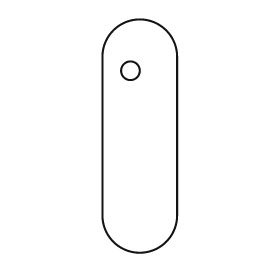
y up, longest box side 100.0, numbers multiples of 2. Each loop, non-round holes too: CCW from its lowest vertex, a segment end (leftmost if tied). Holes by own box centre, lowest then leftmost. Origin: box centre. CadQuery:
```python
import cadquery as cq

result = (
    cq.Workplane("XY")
    .moveTo(-16.0, -34.0)
    .threePointArc((0.0, -50.0), (16.0, -34.0))
    .lineTo(16.0, 34.0)
    .threePointArc((0.0, 50.0), (-16.0, 34.0))
    .close()
    .moveTo(-4.0, 28.0)
    .circle(4.0)
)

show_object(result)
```